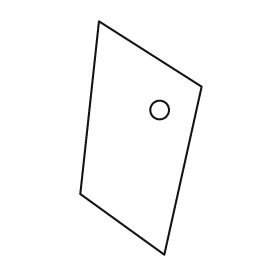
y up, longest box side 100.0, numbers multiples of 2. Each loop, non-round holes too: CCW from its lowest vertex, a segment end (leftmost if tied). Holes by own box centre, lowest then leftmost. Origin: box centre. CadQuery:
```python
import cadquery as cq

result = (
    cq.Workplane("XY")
    .moveTo(10.0, -50.0)
    .lineTo(26.0, 22.0)
    .lineTo(-18.0, 50.0)
    .lineTo(-26.0, -24.0)
    .close()
    .moveTo(8.0, 12.0)
    .circle(4.0)
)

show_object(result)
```